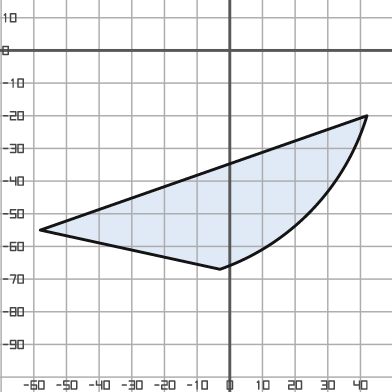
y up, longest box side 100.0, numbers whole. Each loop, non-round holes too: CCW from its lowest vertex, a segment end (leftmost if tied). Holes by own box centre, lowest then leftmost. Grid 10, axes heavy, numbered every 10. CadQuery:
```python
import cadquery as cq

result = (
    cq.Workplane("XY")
    .moveTo(-3.0, -67.0)
    .threePointArc((25.0, -49.0), (42.0, -20.0))
    .lineTo(-58.0, -55.0)
    .close()
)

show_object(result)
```